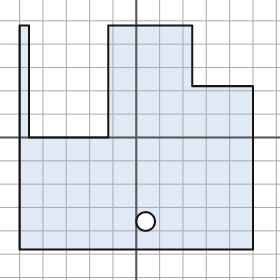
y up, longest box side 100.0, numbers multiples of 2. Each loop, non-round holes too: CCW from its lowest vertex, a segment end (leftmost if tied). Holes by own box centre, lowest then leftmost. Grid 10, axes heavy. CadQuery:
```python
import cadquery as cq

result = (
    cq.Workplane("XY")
    .moveTo(-50.0, -48.0)
    .lineTo(50.0, -48.0)
    .lineTo(50.0, 22.0)
    .lineTo(24.0, 22.0)
    .lineTo(24.0, 48.0)
    .lineTo(-12.0, 48.0)
    .lineTo(-12.0, 0.0)
    .lineTo(-46.0, 0.0)
    .lineTo(-46.0, 48.0)
    .lineTo(-50.0, 48.0)
    .close()
    .moveTo(4.0, -36.0)
    .circle(4.0)
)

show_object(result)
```